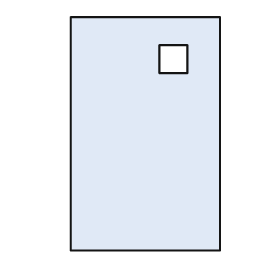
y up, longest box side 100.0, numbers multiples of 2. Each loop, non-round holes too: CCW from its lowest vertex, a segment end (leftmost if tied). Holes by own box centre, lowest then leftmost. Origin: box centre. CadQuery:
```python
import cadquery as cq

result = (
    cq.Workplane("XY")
    .moveTo(-32.0, -50.0)
    .lineTo(32.0, -50.0)
    .lineTo(32.0, 50.0)
    .lineTo(-32.0, 50.0)
    .close()
    .moveTo(6.0, 26.0)
    .lineTo(18.0, 26.0)
    .lineTo(18.0, 38.0)
    .lineTo(6.0, 38.0)
    .close()
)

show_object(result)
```